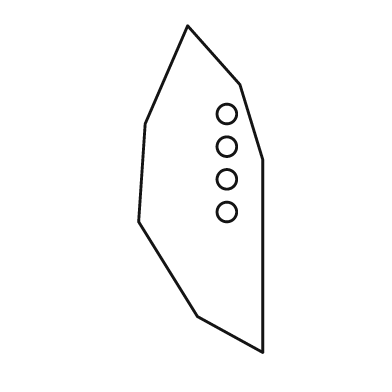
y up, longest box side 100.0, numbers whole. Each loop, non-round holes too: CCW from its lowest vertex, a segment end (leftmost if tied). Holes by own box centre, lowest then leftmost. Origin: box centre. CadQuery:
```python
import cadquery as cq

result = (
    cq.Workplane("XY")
    .moveTo(19.0, -50.0)
    .lineTo(19.0, 9.0)
    .lineTo(12.0, 32.0)
    .lineTo(-4.0, 50.0)
    .lineTo(-17.0, 20.0)
    .lineTo(-19.0, -10.0)
    .lineTo(-1.0, -39.0)
    .close()
    .moveTo(8.0, -7.0)
    .circle(3.0)
    .moveTo(8.0, 3.0)
    .circle(3.0)
    .moveTo(8.0, 13.0)
    .circle(3.0)
    .moveTo(8.0, 23.0)
    .circle(3.0)
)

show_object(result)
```